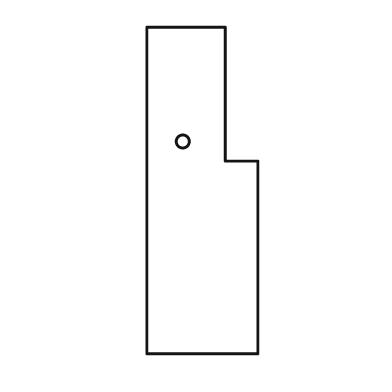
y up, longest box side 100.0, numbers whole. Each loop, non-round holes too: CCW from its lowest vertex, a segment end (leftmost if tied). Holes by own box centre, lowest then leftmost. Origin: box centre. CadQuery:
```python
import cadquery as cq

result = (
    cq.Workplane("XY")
    .moveTo(-17.0, -50.0)
    .lineTo(17.0, -50.0)
    .lineTo(17.0, 9.0)
    .lineTo(7.0, 9.0)
    .lineTo(7.0, 50.0)
    .lineTo(-17.0, 50.0)
    .close()
    .moveTo(-6.0, 15.0)
    .circle(2.0)
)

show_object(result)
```